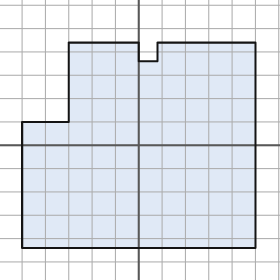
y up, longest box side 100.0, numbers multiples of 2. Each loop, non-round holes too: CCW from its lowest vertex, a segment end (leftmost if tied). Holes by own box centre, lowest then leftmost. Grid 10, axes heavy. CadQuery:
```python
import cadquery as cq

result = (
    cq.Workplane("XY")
    .moveTo(-50.0, -44.0)
    .lineTo(50.0, -44.0)
    .lineTo(50.0, 44.0)
    .lineTo(8.0, 44.0)
    .lineTo(8.0, 36.0)
    .lineTo(0.0, 36.0)
    .lineTo(0.0, 44.0)
    .lineTo(-30.0, 44.0)
    .lineTo(-30.0, 10.0)
    .lineTo(-50.0, 10.0)
    .close()
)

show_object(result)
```